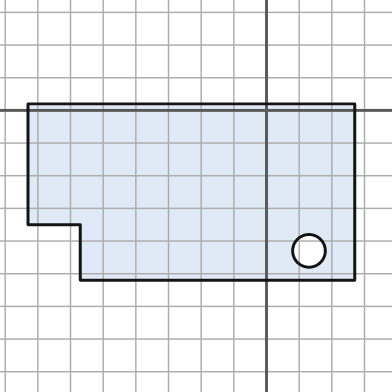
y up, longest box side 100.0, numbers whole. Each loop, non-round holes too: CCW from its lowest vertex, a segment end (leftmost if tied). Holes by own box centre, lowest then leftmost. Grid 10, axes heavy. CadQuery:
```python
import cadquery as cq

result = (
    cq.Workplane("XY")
    .moveTo(-57.0, -52.0)
    .lineTo(27.0, -52.0)
    .lineTo(27.0, 2.0)
    .lineTo(-73.0, 2.0)
    .lineTo(-73.0, -35.0)
    .lineTo(-57.0, -35.0)
    .close()
    .moveTo(13.0, -43.0)
    .circle(5.0)
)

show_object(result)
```